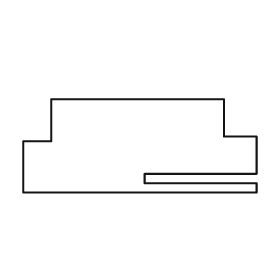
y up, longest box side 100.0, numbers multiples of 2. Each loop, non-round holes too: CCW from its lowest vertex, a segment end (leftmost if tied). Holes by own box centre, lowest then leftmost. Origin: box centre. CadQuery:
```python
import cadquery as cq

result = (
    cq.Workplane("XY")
    .moveTo(-50.0, -20.0)
    .lineTo(50.0, -20.0)
    .lineTo(50.0, -16.0)
    .lineTo(2.0, -16.0)
    .lineTo(2.0, -12.0)
    .lineTo(50.0, -12.0)
    .lineTo(50.0, 4.0)
    .lineTo(36.0, 4.0)
    .lineTo(36.0, 20.0)
    .lineTo(-38.0, 20.0)
    .lineTo(-38.0, 2.0)
    .lineTo(-50.0, 2.0)
    .close()
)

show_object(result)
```